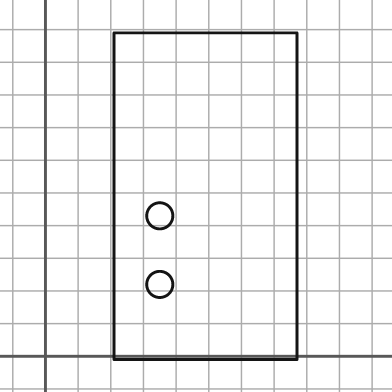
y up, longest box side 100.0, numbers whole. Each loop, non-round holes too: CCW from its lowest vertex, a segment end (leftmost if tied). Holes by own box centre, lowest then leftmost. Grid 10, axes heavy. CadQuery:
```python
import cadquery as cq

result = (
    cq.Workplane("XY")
    .moveTo(21.0, -1.0)
    .lineTo(77.0, -1.0)
    .lineTo(77.0, 99.0)
    .lineTo(21.0, 99.0)
    .close()
    .moveTo(35.0, 22.0)
    .circle(4.0)
    .moveTo(35.0, 43.0)
    .circle(4.0)
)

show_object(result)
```